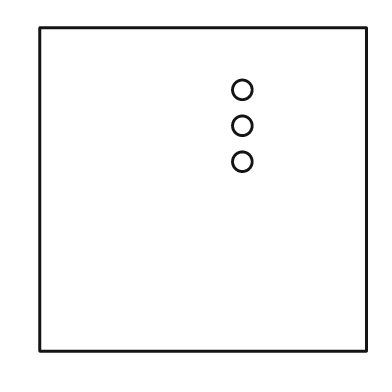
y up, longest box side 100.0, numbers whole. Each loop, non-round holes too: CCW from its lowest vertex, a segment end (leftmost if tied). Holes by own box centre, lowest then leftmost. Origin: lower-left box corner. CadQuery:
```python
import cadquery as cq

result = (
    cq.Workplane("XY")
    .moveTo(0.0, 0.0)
    .lineTo(100.0, 0.0)
    .lineTo(100.0, 99.0)
    .lineTo(0.0, 99.0)
    .close()
    .moveTo(62.0, 58.0)
    .circle(3.0)
    .moveTo(62.0, 69.0)
    .circle(3.0)
    .moveTo(62.0, 80.0)
    .circle(3.0)
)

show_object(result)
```